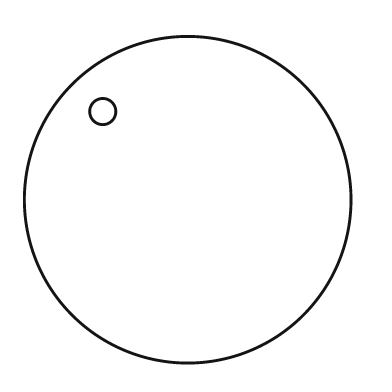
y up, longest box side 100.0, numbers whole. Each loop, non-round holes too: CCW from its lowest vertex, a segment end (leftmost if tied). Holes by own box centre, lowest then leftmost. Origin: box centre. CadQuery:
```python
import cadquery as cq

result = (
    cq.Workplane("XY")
    .moveTo(0.0, 0.0)
    .circle(50.0)
    .moveTo(-26.0, 27.0)
    .circle(4.0)
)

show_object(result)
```